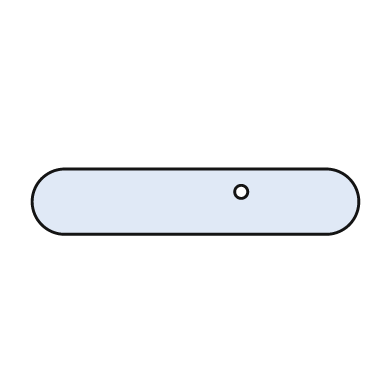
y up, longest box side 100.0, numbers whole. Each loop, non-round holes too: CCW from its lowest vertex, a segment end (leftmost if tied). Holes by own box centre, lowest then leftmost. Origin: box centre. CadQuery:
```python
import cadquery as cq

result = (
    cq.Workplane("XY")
    .moveTo(-40.0, -10.0)
    .lineTo(40.0, -10.0)
    .threePointArc((50.0, 0.0), (40.0, 10.0))
    .lineTo(-40.0, 10.0)
    .threePointArc((-50.0, 0.0), (-40.0, -10.0))
    .close()
    .moveTo(14.0, 3.0)
    .circle(2.0)
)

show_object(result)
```